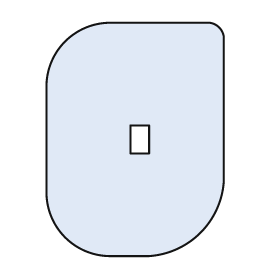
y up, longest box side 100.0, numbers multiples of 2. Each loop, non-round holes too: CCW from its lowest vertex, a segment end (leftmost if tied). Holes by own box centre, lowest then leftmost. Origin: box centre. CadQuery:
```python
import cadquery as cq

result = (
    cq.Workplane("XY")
    .moveTo(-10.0, -50.0)
    .lineTo(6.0, -50.0)
    .threePointArc((28.0, -40.0), (38.0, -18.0))
    .lineTo(38.0, 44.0)
    .threePointArc((36.0, 48.0), (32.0, 50.0))
    .lineTo(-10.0, 50.0)
    .threePointArc((-30.0, 42.0), (-38.0, 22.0))
    .lineTo(-38.0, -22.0)
    .threePointArc((-30.0, -42.0), (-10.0, -50.0))
    .close()
    .moveTo(-2.0, -6.0)
    .lineTo(6.0, -6.0)
    .lineTo(6.0, 6.0)
    .lineTo(-2.0, 6.0)
    .close()
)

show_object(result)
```